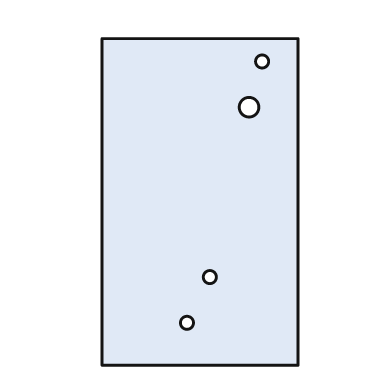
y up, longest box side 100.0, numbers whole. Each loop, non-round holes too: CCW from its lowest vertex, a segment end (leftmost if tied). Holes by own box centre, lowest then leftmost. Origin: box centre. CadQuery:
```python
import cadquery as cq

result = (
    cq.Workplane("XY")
    .moveTo(-30.0, -50.0)
    .lineTo(30.0, -50.0)
    .lineTo(30.0, 50.0)
    .lineTo(-30.0, 50.0)
    .close()
    .moveTo(-4.0, -37.0)
    .circle(2.0)
    .moveTo(3.0, -23.0)
    .circle(2.0)
    .moveTo(15.0, 29.0)
    .circle(3.0)
    .moveTo(19.0, 43.0)
    .circle(2.0)
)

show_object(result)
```